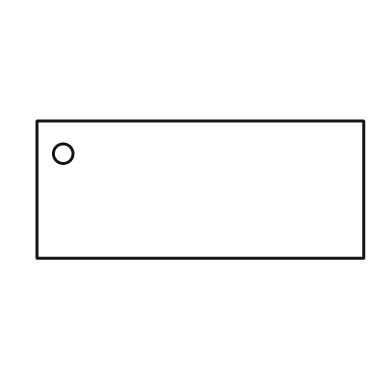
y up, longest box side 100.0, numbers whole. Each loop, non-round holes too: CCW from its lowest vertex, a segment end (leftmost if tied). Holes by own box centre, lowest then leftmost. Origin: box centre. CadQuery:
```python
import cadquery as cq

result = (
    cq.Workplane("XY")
    .moveTo(-50.0, -21.0)
    .lineTo(50.0, -21.0)
    .lineTo(50.0, 21.0)
    .lineTo(-50.0, 21.0)
    .close()
    .moveTo(-42.0, 11.0)
    .circle(3.0)
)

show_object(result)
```